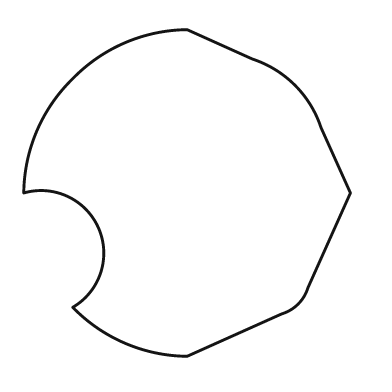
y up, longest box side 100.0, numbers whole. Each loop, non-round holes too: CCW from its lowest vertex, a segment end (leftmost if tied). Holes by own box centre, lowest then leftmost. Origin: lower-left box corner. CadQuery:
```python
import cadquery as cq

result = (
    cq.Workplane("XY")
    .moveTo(50.0, 0.0)
    .lineTo(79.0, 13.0)
    .threePointArc((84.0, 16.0), (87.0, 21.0))
    .lineTo(100.0, 50.0)
    .lineTo(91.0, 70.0)
    .threePointArc((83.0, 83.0), (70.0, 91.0))
    .lineTo(50.0, 100.0)
    .threePointArc((31.0, 96.0), (15.0, 85.0))
    .threePointArc((4.0, 69.0), (0.0, 50.0))
    .threePointArc((23.0, 39.0), (15.0, 15.0))
    .threePointArc((31.0, 4.0), (50.0, 0.0))
    .close()
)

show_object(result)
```